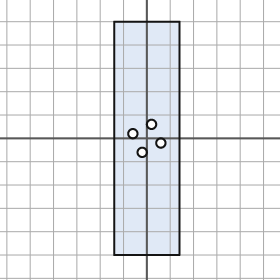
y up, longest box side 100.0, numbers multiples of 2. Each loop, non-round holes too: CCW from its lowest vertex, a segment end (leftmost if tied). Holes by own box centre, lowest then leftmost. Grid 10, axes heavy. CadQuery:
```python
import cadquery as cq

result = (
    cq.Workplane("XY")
    .moveTo(-14.0, -50.0)
    .lineTo(14.0, -50.0)
    .lineTo(14.0, 50.0)
    .lineTo(-14.0, 50.0)
    .close()
    .moveTo(-2.0, -6.0)
    .circle(2.0)
    .moveTo(6.0, -2.0)
    .circle(2.0)
    .moveTo(-6.0, 2.0)
    .circle(2.0)
    .moveTo(2.0, 6.0)
    .circle(2.0)
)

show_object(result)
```